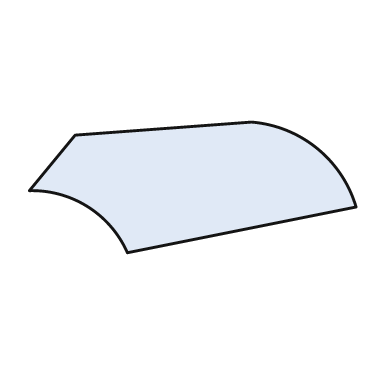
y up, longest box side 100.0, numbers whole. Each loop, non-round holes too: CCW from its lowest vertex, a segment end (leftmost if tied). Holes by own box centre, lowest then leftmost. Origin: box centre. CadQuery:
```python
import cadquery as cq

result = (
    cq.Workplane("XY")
    .moveTo(-20.0, -20.0)
    .lineTo(50.0, -6.0)
    .threePointArc((38.0, 12.0), (18.0, 20.0))
    .lineTo(-36.0, 16.0)
    .lineTo(-50.0, -1.0)
    .threePointArc((-32.0, -6.0), (-20.0, -20.0))
    .close()
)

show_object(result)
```